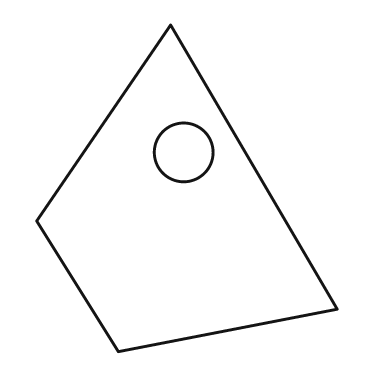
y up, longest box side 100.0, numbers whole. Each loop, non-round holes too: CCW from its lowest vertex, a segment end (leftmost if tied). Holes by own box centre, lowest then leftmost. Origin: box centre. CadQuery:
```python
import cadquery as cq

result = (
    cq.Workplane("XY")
    .moveTo(-21.0, -50.0)
    .lineTo(46.0, -37.0)
    .lineTo(-5.0, 50.0)
    .lineTo(-46.0, -10.0)
    .close()
    .moveTo(-1.0, 11.0)
    .circle(9.0)
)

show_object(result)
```